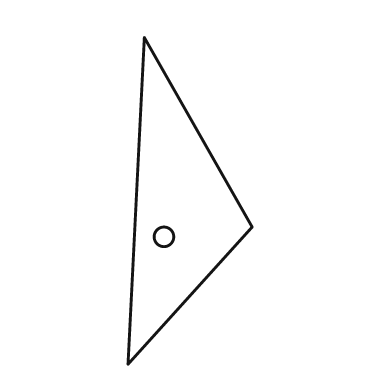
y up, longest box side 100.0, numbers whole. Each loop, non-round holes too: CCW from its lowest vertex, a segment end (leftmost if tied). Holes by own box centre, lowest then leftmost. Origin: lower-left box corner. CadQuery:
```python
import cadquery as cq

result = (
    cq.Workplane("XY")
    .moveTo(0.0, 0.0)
    .lineTo(38.0, 42.0)
    .lineTo(5.0, 100.0)
    .close()
    .moveTo(11.0, 39.0)
    .circle(3.0)
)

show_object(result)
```